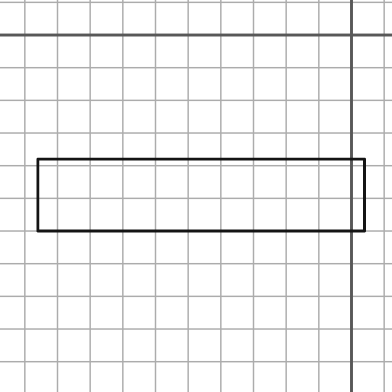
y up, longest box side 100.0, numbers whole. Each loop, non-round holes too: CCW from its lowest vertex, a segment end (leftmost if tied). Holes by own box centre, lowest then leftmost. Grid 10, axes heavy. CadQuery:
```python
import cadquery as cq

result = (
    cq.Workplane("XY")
    .moveTo(-96.0, -60.0)
    .lineTo(4.0, -60.0)
    .lineTo(4.0, -38.0)
    .lineTo(-96.0, -38.0)
    .close()
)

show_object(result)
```